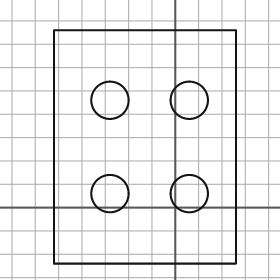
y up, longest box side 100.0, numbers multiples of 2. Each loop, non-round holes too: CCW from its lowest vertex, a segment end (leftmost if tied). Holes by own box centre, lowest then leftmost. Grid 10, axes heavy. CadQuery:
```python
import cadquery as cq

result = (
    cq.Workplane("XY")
    .moveTo(-52.0, -24.0)
    .lineTo(26.0, -24.0)
    .lineTo(26.0, 76.0)
    .lineTo(-52.0, 76.0)
    .close()
    .moveTo(-28.0, 6.0)
    .circle(8.0)
    .moveTo(6.0, 6.0)
    .circle(8.0)
    .moveTo(-28.0, 46.0)
    .circle(8.0)
    .moveTo(6.0, 46.0)
    .circle(8.0)
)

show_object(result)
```